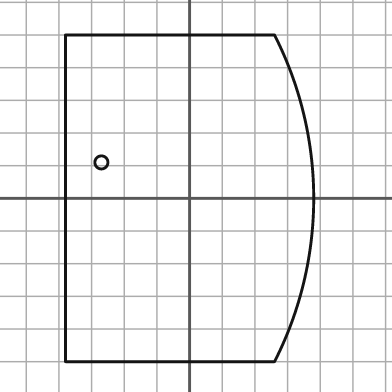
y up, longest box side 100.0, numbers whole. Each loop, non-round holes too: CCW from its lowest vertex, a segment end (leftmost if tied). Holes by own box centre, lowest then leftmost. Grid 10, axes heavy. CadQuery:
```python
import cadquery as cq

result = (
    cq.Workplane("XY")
    .moveTo(-38.0, -50.0)
    .lineTo(26.0, -50.0)
    .threePointArc((38.0, 0.0), (26.0, 50.0))
    .lineTo(-38.0, 50.0)
    .close()
    .moveTo(-27.0, 11.0)
    .circle(2.0)
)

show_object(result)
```